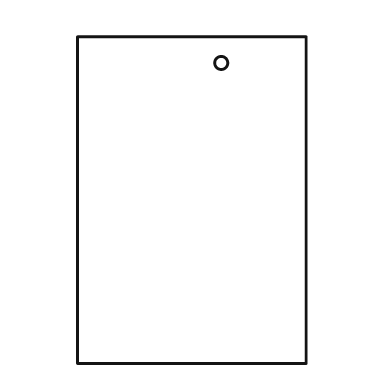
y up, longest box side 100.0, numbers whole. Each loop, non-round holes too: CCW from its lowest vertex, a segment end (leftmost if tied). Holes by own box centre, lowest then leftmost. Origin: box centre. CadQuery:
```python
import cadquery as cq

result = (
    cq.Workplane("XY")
    .moveTo(-35.0, -50.0)
    .lineTo(35.0, -50.0)
    .lineTo(35.0, 50.0)
    .lineTo(-35.0, 50.0)
    .close()
    .moveTo(9.0, 42.0)
    .circle(2.0)
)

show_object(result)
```